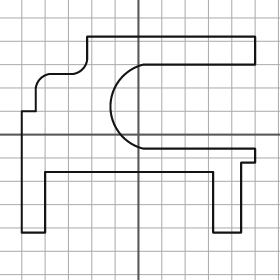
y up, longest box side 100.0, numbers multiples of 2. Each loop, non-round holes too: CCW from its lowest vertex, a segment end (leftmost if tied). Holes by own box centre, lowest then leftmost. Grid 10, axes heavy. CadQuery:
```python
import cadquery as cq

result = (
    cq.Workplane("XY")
    .moveTo(-50.0, -42.0)
    .lineTo(-40.0, -42.0)
    .lineTo(-40.0, -16.0)
    .lineTo(32.0, -16.0)
    .lineTo(32.0, -42.0)
    .lineTo(44.0, -42.0)
    .lineTo(44.0, -12.0)
    .lineTo(50.0, -12.0)
    .lineTo(50.0, -6.0)
    .lineTo(2.0, -6.0)
    .threePointArc((-12.0, 12.0), (2.0, 30.0))
    .lineTo(50.0, 30.0)
    .lineTo(50.0, 42.0)
    .lineTo(-22.0, 42.0)
    .lineTo(-22.0, 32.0)
    .threePointArc((-24.0, 28.0), (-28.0, 26.0))
    .lineTo(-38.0, 26.0)
    .threePointArc((-42.0, 24.0), (-44.0, 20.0))
    .lineTo(-44.0, 10.0)
    .lineTo(-50.0, 10.0)
    .close()
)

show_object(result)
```